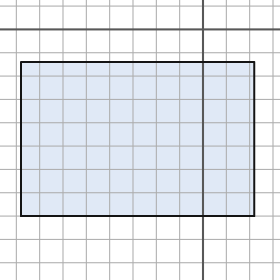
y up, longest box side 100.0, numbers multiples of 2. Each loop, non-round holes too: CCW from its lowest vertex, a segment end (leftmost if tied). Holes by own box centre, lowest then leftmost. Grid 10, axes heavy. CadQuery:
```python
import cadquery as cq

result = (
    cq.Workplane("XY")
    .moveTo(-78.0, -80.0)
    .lineTo(22.0, -80.0)
    .lineTo(22.0, -14.0)
    .lineTo(-78.0, -14.0)
    .close()
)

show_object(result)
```